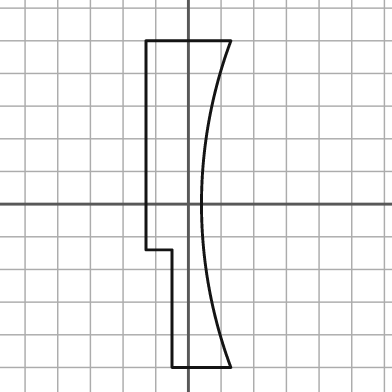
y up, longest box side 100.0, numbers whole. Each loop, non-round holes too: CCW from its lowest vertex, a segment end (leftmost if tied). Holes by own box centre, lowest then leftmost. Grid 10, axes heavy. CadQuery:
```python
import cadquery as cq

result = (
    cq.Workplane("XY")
    .moveTo(-5.0, -50.0)
    .lineTo(13.0, -50.0)
    .threePointArc((4.0, 0.0), (13.0, 50.0))
    .lineTo(-13.0, 50.0)
    .lineTo(-13.0, -14.0)
    .lineTo(-5.0, -14.0)
    .close()
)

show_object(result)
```